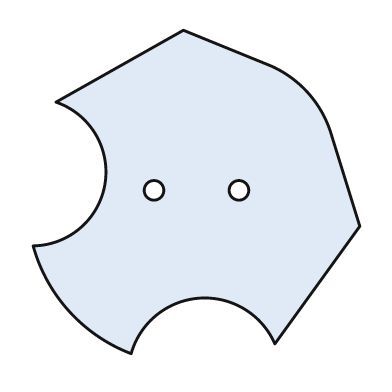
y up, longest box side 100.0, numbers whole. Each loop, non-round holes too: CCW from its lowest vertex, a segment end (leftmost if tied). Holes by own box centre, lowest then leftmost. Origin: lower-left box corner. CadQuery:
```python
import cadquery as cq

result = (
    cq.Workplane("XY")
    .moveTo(30.0, 0.0)
    .threePointArc((51.0, 17.0), (74.0, 3.0))
    .lineTo(100.0, 39.0)
    .lineTo(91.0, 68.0)
    .threePointArc((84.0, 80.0), (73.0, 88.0))
    .lineTo(46.0, 99.0)
    .lineTo(7.0, 77.0)
    .threePointArc((22.0, 52.0), (0.0, 33.0))
    .threePointArc((11.0, 13.0), (30.0, 0.0))
    .close()
    .moveTo(37.0, 50.0)
    .circle(3.0)
    .moveTo(63.0, 50.0)
    .circle(3.0)
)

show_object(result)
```